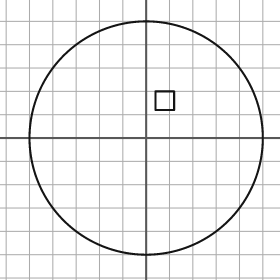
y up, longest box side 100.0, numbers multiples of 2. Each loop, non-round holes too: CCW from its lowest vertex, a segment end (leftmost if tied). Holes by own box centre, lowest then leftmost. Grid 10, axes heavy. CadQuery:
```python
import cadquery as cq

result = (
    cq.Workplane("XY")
    .moveTo(0.0, 0.0)
    .circle(50.0)
    .moveTo(4.0, 12.0)
    .lineTo(12.0, 12.0)
    .lineTo(12.0, 20.0)
    .lineTo(4.0, 20.0)
    .close()
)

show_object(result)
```